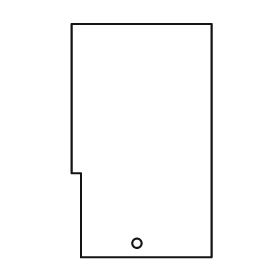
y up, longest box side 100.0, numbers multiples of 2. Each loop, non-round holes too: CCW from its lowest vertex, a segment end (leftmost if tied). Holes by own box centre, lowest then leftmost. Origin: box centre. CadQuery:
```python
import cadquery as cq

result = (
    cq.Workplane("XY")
    .moveTo(-26.0, -50.0)
    .lineTo(30.0, -50.0)
    .lineTo(30.0, 50.0)
    .lineTo(-30.0, 50.0)
    .lineTo(-30.0, -14.0)
    .lineTo(-26.0, -14.0)
    .close()
    .moveTo(-2.0, -44.0)
    .circle(2.0)
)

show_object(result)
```